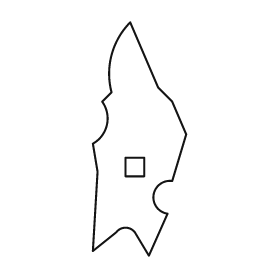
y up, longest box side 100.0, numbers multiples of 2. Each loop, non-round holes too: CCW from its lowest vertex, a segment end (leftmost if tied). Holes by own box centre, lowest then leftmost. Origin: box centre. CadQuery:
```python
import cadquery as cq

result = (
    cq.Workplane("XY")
    .moveTo(4.0, -50.0)
    .lineTo(12.0, -32.0)
    .threePointArc((6.0, -24.0), (14.0, -18.0))
    .lineTo(20.0, 2.0)
    .lineTo(14.0, 16.0)
    .lineTo(8.0, 22.0)
    .lineTo(-4.0, 50.0)
    .threePointArc((-12.0, 36.0), (-12.0, 20.0))
    .lineTo(-16.0, 16.0)
    .threePointArc((-14.0, 6.0), (-20.0, -2.0))
    .lineTo(-18.0, -14.0)
    .lineTo(-20.0, -48.0)
    .lineTo(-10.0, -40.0)
    .threePointArc((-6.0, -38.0), (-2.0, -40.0))
    .close()
    .moveTo(-6.0, -16.0)
    .lineTo(2.0, -16.0)
    .lineTo(2.0, -8.0)
    .lineTo(-6.0, -8.0)
    .close()
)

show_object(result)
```